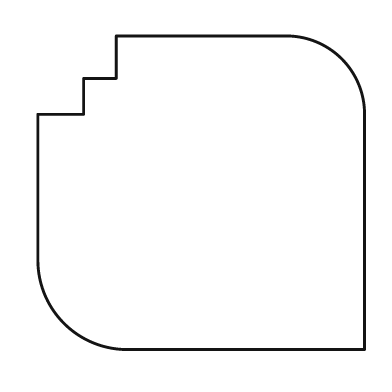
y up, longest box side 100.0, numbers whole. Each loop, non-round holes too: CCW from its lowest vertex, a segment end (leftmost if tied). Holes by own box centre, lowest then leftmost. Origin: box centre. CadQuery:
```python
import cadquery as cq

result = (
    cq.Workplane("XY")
    .moveTo(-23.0, -48.0)
    .lineTo(50.0, -48.0)
    .lineTo(50.0, 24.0)
    .threePointArc((43.0, 41.0), (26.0, 48.0))
    .lineTo(-26.0, 48.0)
    .lineTo(-26.0, 35.0)
    .lineTo(-36.0, 35.0)
    .lineTo(-36.0, 24.0)
    .lineTo(-50.0, 24.0)
    .lineTo(-50.0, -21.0)
    .threePointArc((-42.0, -40.0), (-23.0, -48.0))
    .close()
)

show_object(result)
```